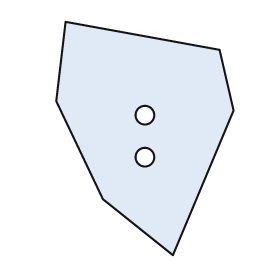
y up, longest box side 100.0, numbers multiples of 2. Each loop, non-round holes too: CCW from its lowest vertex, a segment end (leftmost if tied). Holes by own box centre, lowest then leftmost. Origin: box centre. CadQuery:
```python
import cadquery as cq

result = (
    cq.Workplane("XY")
    .moveTo(12.0, -50.0)
    .lineTo(38.0, 12.0)
    .lineTo(32.0, 38.0)
    .lineTo(-34.0, 50.0)
    .lineTo(-38.0, 16.0)
    .lineTo(-18.0, -26.0)
    .close()
    .moveTo(0.0, -8.0)
    .circle(4.0)
    .moveTo(0.0, 10.0)
    .circle(4.0)
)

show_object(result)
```